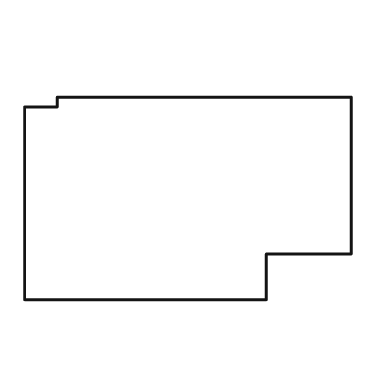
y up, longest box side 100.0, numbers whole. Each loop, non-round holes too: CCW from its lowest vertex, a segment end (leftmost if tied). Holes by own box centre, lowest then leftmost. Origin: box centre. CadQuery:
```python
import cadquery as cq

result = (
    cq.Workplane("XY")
    .moveTo(-50.0, -31.0)
    .lineTo(24.0, -31.0)
    .lineTo(24.0, -17.0)
    .lineTo(50.0, -17.0)
    .lineTo(50.0, 31.0)
    .lineTo(-40.0, 31.0)
    .lineTo(-40.0, 28.0)
    .lineTo(-50.0, 28.0)
    .close()
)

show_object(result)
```